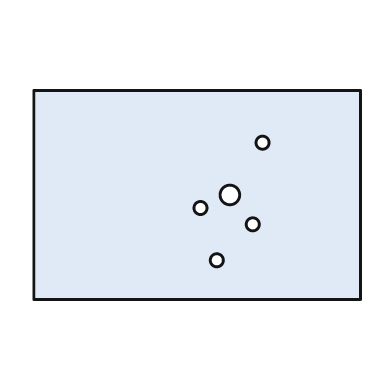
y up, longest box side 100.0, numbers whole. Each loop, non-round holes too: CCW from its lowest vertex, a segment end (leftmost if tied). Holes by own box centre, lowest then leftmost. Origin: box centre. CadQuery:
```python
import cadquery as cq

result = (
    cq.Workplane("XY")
    .moveTo(-50.0, -32.0)
    .lineTo(50.0, -32.0)
    .lineTo(50.0, 32.0)
    .lineTo(-50.0, 32.0)
    .close()
    .moveTo(6.0, -20.0)
    .circle(2.0)
    .moveTo(17.0, -9.0)
    .circle(2.0)
    .moveTo(1.0, -4.0)
    .circle(2.0)
    .moveTo(10.0, 0.0)
    .circle(3.0)
    .moveTo(20.0, 16.0)
    .circle(2.0)
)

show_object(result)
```